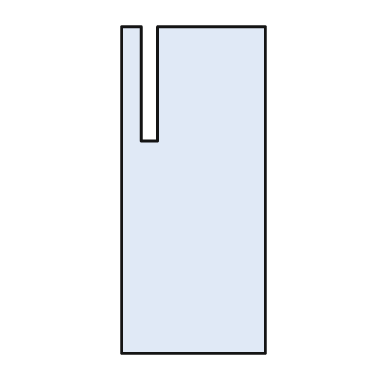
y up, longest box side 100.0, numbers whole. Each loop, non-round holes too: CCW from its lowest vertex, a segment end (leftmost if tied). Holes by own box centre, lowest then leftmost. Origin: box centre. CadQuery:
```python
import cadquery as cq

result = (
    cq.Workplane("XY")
    .moveTo(-22.0, -50.0)
    .lineTo(22.0, -50.0)
    .lineTo(22.0, 50.0)
    .lineTo(-11.0, 50.0)
    .lineTo(-11.0, 15.0)
    .lineTo(-16.0, 15.0)
    .lineTo(-16.0, 50.0)
    .lineTo(-22.0, 50.0)
    .close()
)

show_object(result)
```